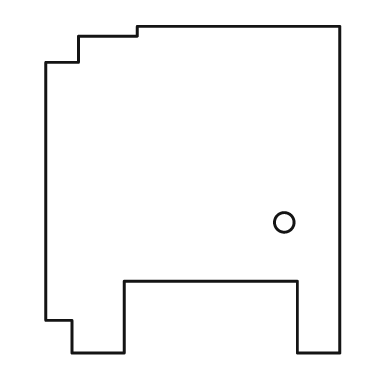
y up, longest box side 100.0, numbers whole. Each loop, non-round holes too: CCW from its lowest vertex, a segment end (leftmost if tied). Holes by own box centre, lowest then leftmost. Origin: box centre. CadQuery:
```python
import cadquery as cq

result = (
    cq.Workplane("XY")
    .moveTo(-37.0, -50.0)
    .lineTo(-21.0, -50.0)
    .lineTo(-21.0, -28.0)
    .lineTo(32.0, -28.0)
    .lineTo(32.0, -50.0)
    .lineTo(45.0, -50.0)
    .lineTo(45.0, 50.0)
    .lineTo(-17.0, 50.0)
    .lineTo(-17.0, 47.0)
    .lineTo(-35.0, 47.0)
    .lineTo(-35.0, 39.0)
    .lineTo(-45.0, 39.0)
    .lineTo(-45.0, -40.0)
    .lineTo(-37.0, -40.0)
    .close()
    .moveTo(28.0, -10.0)
    .circle(3.0)
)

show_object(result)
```